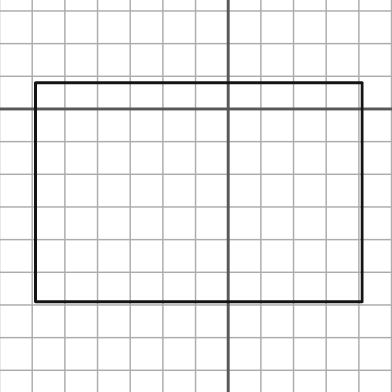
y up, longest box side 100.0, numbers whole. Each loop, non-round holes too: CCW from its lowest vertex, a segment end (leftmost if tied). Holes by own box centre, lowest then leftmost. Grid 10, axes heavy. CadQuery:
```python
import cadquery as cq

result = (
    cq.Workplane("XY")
    .moveTo(-59.0, -59.0)
    .lineTo(41.0, -59.0)
    .lineTo(41.0, 8.0)
    .lineTo(-59.0, 8.0)
    .close()
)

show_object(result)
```